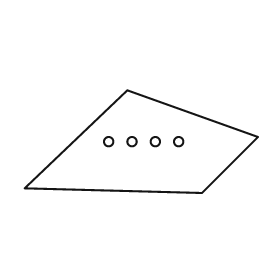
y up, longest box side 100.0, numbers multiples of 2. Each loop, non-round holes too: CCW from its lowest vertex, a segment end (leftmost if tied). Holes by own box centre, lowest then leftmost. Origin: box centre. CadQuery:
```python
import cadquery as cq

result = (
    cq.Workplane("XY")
    .moveTo(26.0, -22.0)
    .lineTo(50.0, 2.0)
    .lineTo(-6.0, 22.0)
    .lineTo(-50.0, -20.0)
    .close()
    .moveTo(-14.0, 0.0)
    .circle(2.0)
    .moveTo(-4.0, 0.0)
    .circle(2.0)
    .moveTo(6.0, 0.0)
    .circle(2.0)
    .moveTo(16.0, 0.0)
    .circle(2.0)
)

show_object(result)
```